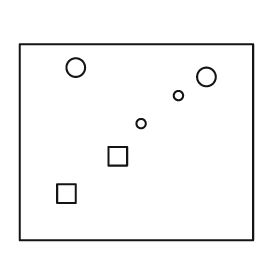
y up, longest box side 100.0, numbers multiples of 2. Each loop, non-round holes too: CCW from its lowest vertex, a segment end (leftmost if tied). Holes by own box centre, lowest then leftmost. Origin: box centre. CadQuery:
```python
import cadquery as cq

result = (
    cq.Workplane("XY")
    .moveTo(-50.0, -42.0)
    .lineTo(50.0, -42.0)
    .lineTo(50.0, 42.0)
    .lineTo(-50.0, 42.0)
    .close()
    .moveTo(-34.0, -26.0)
    .lineTo(-26.0, -26.0)
    .lineTo(-26.0, -18.0)
    .lineTo(-34.0, -18.0)
    .close()
    .moveTo(-12.0, -10.0)
    .lineTo(-4.0, -10.0)
    .lineTo(-4.0, -2.0)
    .lineTo(-12.0, -2.0)
    .close()
    .moveTo(2.0, 8.0)
    .circle(2.0)
    .moveTo(18.0, 20.0)
    .circle(2.0)
    .moveTo(30.0, 28.0)
    .circle(4.0)
    .moveTo(-26.0, 32.0)
    .circle(4.0)
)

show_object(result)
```